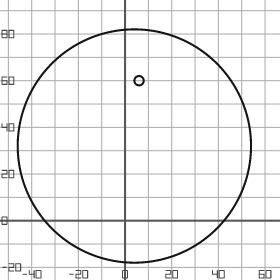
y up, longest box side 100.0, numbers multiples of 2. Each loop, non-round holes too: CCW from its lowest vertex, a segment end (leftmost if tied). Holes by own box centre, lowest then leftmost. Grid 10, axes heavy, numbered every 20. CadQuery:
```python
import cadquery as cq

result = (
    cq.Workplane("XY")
    .moveTo(4.0, 32.0)
    .circle(50.0)
    .moveTo(6.0, 60.0)
    .circle(2.0)
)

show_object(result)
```